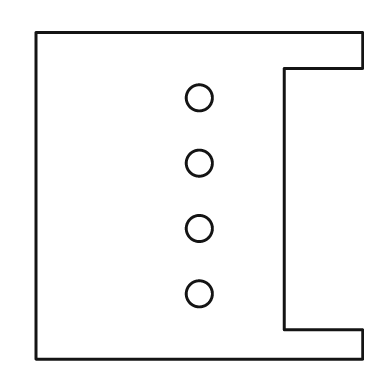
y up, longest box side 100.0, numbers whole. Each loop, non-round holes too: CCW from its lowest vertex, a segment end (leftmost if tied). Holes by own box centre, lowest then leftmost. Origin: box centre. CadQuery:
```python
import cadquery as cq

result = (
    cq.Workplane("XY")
    .moveTo(-50.0, -50.0)
    .lineTo(50.0, -50.0)
    .lineTo(50.0, -41.0)
    .lineTo(26.0, -41.0)
    .lineTo(26.0, 39.0)
    .lineTo(50.0, 39.0)
    .lineTo(50.0, 50.0)
    .lineTo(-50.0, 50.0)
    .close()
    .moveTo(0.0, -30.0)
    .circle(4.0)
    .moveTo(0.0, -10.0)
    .circle(4.0)
    .moveTo(0.0, 10.0)
    .circle(4.0)
    .moveTo(0.0, 30.0)
    .circle(4.0)
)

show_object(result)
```